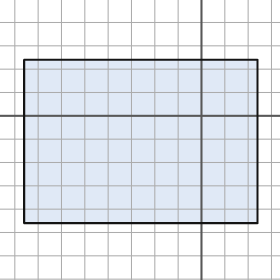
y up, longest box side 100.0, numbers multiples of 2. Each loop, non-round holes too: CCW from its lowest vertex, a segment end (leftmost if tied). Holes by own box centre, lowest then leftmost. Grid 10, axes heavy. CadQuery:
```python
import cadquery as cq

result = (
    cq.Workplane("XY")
    .moveTo(-76.0, -46.0)
    .lineTo(24.0, -46.0)
    .lineTo(24.0, 24.0)
    .lineTo(-76.0, 24.0)
    .close()
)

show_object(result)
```